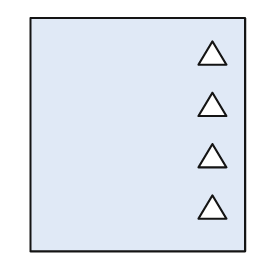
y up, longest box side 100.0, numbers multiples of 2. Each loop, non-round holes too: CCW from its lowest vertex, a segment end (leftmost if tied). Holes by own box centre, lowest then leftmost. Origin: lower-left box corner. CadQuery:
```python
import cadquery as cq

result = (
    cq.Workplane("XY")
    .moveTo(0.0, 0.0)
    .lineTo(92.0, 0.0)
    .lineTo(92.0, 100.0)
    .lineTo(0.0, 100.0)
    .close()
    .moveTo(72.0, 14.0)
    .lineTo(84.0, 14.0)
    .lineTo(78.0, 24.0)
    .close()
    .moveTo(72.0, 36.0)
    .lineTo(84.0, 36.0)
    .lineTo(78.0, 46.0)
    .close()
    .moveTo(72.0, 58.0)
    .lineTo(84.0, 58.0)
    .lineTo(78.0, 68.0)
    .close()
    .moveTo(72.0, 80.0)
    .lineTo(84.0, 80.0)
    .lineTo(78.0, 90.0)
    .close()
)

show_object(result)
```